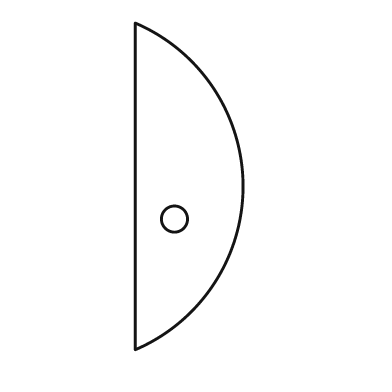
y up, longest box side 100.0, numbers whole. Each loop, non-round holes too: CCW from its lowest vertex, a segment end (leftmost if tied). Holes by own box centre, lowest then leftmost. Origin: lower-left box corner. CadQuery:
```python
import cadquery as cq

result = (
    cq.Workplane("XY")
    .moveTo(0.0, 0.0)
    .threePointArc((33.0, 50.0), (0.0, 100.0))
    .close()
    .moveTo(12.0, 40.0)
    .circle(4.0)
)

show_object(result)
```